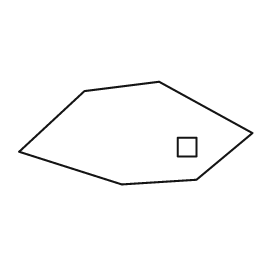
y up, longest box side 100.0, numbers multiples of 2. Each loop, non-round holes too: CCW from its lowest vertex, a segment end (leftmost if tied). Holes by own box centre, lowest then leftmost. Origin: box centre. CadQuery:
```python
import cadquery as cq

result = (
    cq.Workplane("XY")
    .moveTo(-6.0, -22.0)
    .lineTo(26.0, -20.0)
    .lineTo(50.0, 0.0)
    .lineTo(10.0, 22.0)
    .lineTo(-22.0, 18.0)
    .lineTo(-50.0, -8.0)
    .close()
    .moveTo(18.0, -10.0)
    .lineTo(26.0, -10.0)
    .lineTo(26.0, -2.0)
    .lineTo(18.0, -2.0)
    .close()
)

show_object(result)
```